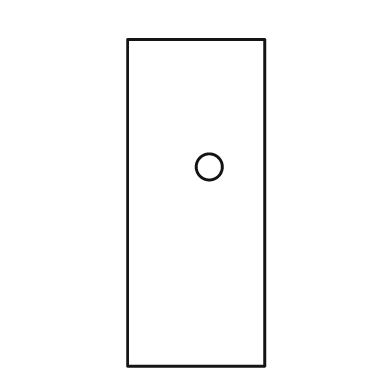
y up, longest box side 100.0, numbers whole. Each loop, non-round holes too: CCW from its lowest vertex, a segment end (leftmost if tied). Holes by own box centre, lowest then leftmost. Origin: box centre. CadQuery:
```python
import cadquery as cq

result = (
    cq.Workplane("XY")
    .moveTo(-21.0, -50.0)
    .lineTo(21.0, -50.0)
    .lineTo(21.0, 50.0)
    .lineTo(-21.0, 50.0)
    .close()
    .moveTo(4.0, 11.0)
    .circle(4.0)
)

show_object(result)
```